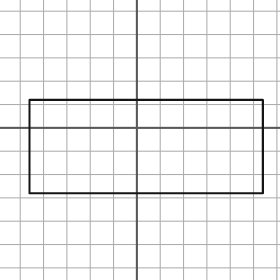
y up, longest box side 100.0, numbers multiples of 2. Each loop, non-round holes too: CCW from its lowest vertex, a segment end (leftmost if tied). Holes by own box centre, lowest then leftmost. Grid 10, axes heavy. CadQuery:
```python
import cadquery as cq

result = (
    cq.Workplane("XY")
    .moveTo(-46.0, -28.0)
    .lineTo(54.0, -28.0)
    .lineTo(54.0, 12.0)
    .lineTo(-46.0, 12.0)
    .close()
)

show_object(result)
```